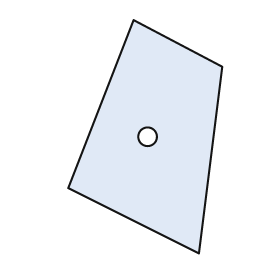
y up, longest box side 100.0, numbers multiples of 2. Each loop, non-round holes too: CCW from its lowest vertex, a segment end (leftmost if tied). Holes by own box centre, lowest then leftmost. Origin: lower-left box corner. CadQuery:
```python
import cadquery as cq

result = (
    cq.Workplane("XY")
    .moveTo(56.0, 0.0)
    .lineTo(66.0, 80.0)
    .lineTo(28.0, 100.0)
    .lineTo(0.0, 28.0)
    .close()
    .moveTo(34.0, 50.0)
    .circle(4.0)
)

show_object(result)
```